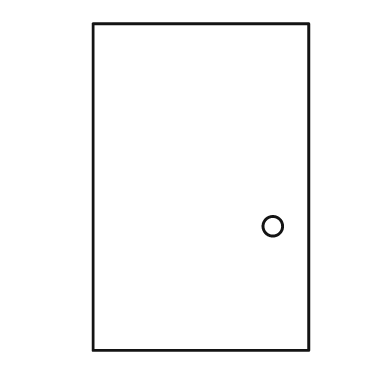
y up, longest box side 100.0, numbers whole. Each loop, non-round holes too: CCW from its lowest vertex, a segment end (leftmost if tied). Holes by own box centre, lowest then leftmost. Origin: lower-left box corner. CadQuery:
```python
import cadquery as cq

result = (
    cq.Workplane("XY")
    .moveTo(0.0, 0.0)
    .lineTo(66.0, 0.0)
    .lineTo(66.0, 100.0)
    .lineTo(0.0, 100.0)
    .close()
    .moveTo(55.0, 38.0)
    .circle(3.0)
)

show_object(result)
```